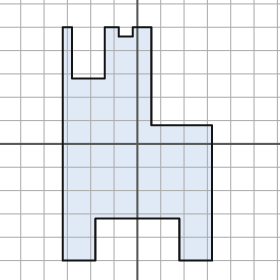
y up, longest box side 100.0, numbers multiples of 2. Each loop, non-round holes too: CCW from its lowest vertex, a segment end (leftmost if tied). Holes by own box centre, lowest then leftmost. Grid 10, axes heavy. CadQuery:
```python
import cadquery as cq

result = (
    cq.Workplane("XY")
    .moveTo(-32.0, -50.0)
    .lineTo(-18.0, -50.0)
    .lineTo(-18.0, -32.0)
    .lineTo(18.0, -32.0)
    .lineTo(18.0, -50.0)
    .lineTo(32.0, -50.0)
    .lineTo(32.0, 8.0)
    .lineTo(6.0, 8.0)
    .lineTo(6.0, 50.0)
    .lineTo(-2.0, 50.0)
    .lineTo(-2.0, 46.0)
    .lineTo(-8.0, 46.0)
    .lineTo(-8.0, 50.0)
    .lineTo(-14.0, 50.0)
    .lineTo(-14.0, 28.0)
    .lineTo(-28.0, 28.0)
    .lineTo(-28.0, 50.0)
    .lineTo(-32.0, 50.0)
    .close()
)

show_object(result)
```